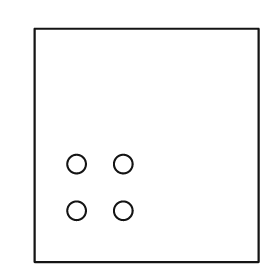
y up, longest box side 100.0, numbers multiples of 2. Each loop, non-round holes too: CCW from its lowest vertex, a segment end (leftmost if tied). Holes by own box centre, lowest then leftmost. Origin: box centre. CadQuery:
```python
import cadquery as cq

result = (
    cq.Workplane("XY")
    .moveTo(-48.0, -50.0)
    .lineTo(48.0, -50.0)
    .lineTo(48.0, 50.0)
    .lineTo(-48.0, 50.0)
    .close()
    .moveTo(-30.0, -28.0)
    .circle(4.0)
    .moveTo(-10.0, -28.0)
    .circle(4.0)
    .moveTo(-30.0, -8.0)
    .circle(4.0)
    .moveTo(-10.0, -8.0)
    .circle(4.0)
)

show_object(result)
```